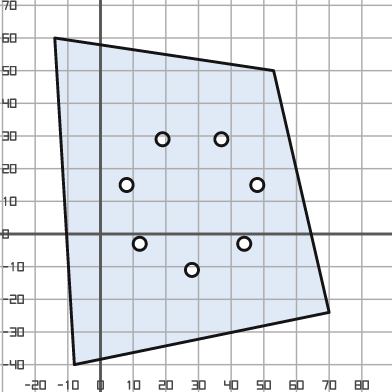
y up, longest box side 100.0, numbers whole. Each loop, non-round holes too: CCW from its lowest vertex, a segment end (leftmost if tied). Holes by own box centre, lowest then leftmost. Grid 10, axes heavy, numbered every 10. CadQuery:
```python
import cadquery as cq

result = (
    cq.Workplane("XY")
    .moveTo(-8.0, -40.0)
    .lineTo(70.0, -24.0)
    .lineTo(53.0, 50.0)
    .lineTo(-14.0, 60.0)
    .close()
    .moveTo(28.0, -11.0)
    .circle(2.0)
    .moveTo(12.0, -3.0)
    .circle(2.0)
    .moveTo(44.0, -3.0)
    .circle(2.0)
    .moveTo(8.0, 15.0)
    .circle(2.0)
    .moveTo(48.0, 15.0)
    .circle(2.0)
    .moveTo(19.0, 29.0)
    .circle(2.0)
    .moveTo(37.0, 29.0)
    .circle(2.0)
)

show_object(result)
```